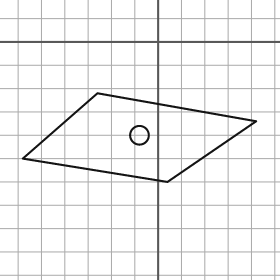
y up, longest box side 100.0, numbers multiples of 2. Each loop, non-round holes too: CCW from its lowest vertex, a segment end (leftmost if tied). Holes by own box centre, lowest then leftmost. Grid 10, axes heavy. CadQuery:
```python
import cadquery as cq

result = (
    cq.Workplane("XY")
    .moveTo(4.0, -60.0)
    .lineTo(42.0, -34.0)
    .lineTo(-26.0, -22.0)
    .lineTo(-58.0, -50.0)
    .close()
    .moveTo(-8.0, -40.0)
    .circle(4.0)
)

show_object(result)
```